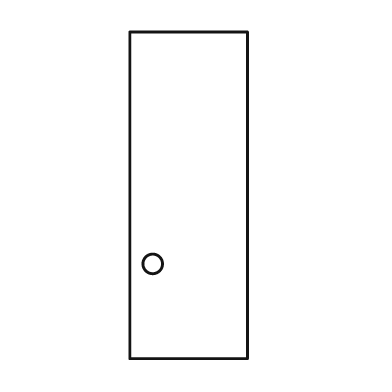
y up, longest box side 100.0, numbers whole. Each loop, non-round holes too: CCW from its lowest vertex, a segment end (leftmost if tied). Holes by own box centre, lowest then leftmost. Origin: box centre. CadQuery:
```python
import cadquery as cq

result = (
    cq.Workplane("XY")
    .moveTo(-18.0, -50.0)
    .lineTo(18.0, -50.0)
    .lineTo(18.0, 50.0)
    .lineTo(-18.0, 50.0)
    .close()
    .moveTo(-11.0, -21.0)
    .circle(3.0)
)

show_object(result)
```